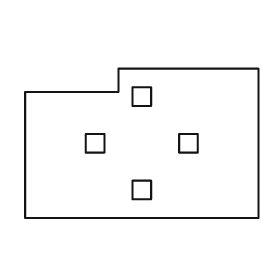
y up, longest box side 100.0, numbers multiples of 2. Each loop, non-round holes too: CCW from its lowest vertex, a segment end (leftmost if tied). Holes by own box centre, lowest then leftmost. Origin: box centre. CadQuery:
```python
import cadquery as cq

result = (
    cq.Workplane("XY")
    .moveTo(-50.0, -32.0)
    .lineTo(50.0, -32.0)
    .lineTo(50.0, 32.0)
    .lineTo(-10.0, 32.0)
    .lineTo(-10.0, 22.0)
    .lineTo(-50.0, 22.0)
    .close()
    .moveTo(-4.0, -24.0)
    .lineTo(4.0, -24.0)
    .lineTo(4.0, -16.0)
    .lineTo(-4.0, -16.0)
    .close()
    .moveTo(-24.0, -4.0)
    .lineTo(-16.0, -4.0)
    .lineTo(-16.0, 4.0)
    .lineTo(-24.0, 4.0)
    .close()
    .moveTo(16.0, -4.0)
    .lineTo(24.0, -4.0)
    .lineTo(24.0, 4.0)
    .lineTo(16.0, 4.0)
    .close()
    .moveTo(-4.0, 16.0)
    .lineTo(4.0, 16.0)
    .lineTo(4.0, 24.0)
    .lineTo(-4.0, 24.0)
    .close()
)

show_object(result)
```